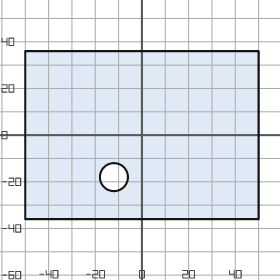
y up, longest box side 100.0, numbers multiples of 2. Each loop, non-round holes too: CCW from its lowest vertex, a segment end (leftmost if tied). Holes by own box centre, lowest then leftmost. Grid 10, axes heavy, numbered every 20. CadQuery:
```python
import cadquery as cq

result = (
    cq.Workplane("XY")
    .moveTo(-50.0, -36.0)
    .lineTo(50.0, -36.0)
    .lineTo(50.0, 36.0)
    .lineTo(-50.0, 36.0)
    .close()
    .moveTo(-12.0, -18.0)
    .circle(6.0)
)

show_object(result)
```